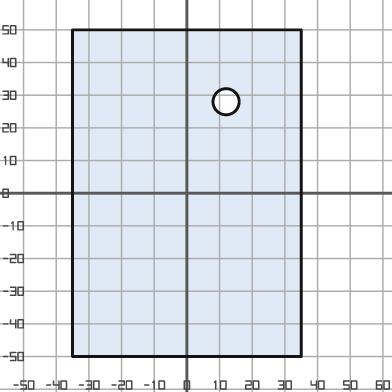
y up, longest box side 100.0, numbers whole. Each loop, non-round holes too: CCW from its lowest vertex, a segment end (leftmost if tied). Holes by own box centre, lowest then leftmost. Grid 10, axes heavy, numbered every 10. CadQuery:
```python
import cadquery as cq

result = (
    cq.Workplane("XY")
    .moveTo(-35.0, -50.0)
    .lineTo(35.0, -50.0)
    .lineTo(35.0, 50.0)
    .lineTo(-35.0, 50.0)
    .close()
    .moveTo(12.0, 28.0)
    .circle(4.0)
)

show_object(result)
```